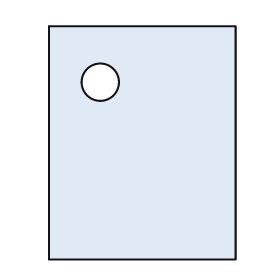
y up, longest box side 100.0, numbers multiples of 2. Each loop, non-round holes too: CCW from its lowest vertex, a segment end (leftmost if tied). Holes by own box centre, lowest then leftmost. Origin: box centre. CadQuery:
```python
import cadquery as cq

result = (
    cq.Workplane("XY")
    .moveTo(-40.0, -50.0)
    .lineTo(40.0, -50.0)
    .lineTo(40.0, 50.0)
    .lineTo(-40.0, 50.0)
    .close()
    .moveTo(-18.0, 26.0)
    .circle(8.0)
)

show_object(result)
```